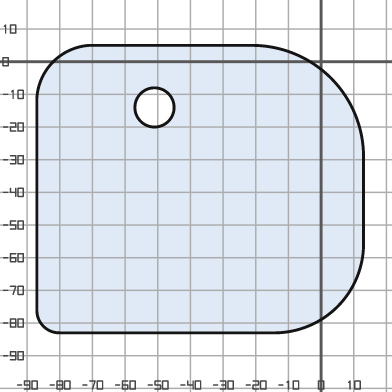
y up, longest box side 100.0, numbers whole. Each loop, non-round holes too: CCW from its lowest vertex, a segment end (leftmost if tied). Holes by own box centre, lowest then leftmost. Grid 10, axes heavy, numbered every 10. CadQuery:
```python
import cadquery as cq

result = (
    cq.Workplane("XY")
    .moveTo(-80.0, -83.0)
    .lineTo(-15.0, -83.0)
    .threePointArc((5.0, -75.0), (13.0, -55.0))
    .lineTo(13.0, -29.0)
    .threePointArc((3.0, -5.0), (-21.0, 5.0))
    .lineTo(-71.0, 5.0)
    .threePointArc((-82.0, 0.0), (-87.0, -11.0))
    .lineTo(-87.0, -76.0)
    .threePointArc((-85.0, -81.0), (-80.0, -83.0))
    .close()
    .moveTo(-51.0, -14.0)
    .circle(6.0)
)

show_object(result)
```